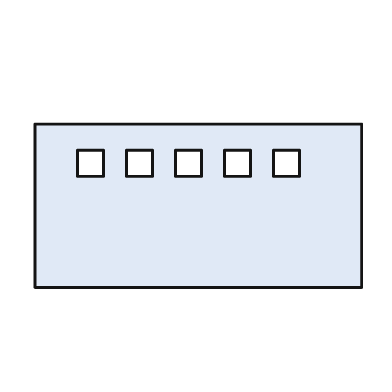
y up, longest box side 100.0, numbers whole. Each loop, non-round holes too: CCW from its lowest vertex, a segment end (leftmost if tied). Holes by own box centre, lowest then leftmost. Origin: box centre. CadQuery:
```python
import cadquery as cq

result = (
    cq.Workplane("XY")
    .moveTo(-50.0, -25.0)
    .lineTo(50.0, -25.0)
    .lineTo(50.0, 25.0)
    .lineTo(-50.0, 25.0)
    .close()
    .moveTo(-37.0, 9.0)
    .lineTo(-29.0, 9.0)
    .lineTo(-29.0, 17.0)
    .lineTo(-37.0, 17.0)
    .close()
    .moveTo(-22.0, 9.0)
    .lineTo(-14.0, 9.0)
    .lineTo(-14.0, 17.0)
    .lineTo(-22.0, 17.0)
    .close()
    .moveTo(-7.0, 9.0)
    .lineTo(1.0, 9.0)
    .lineTo(1.0, 17.0)
    .lineTo(-7.0, 17.0)
    .close()
    .moveTo(8.0, 9.0)
    .lineTo(16.0, 9.0)
    .lineTo(16.0, 17.0)
    .lineTo(8.0, 17.0)
    .close()
    .moveTo(23.0, 9.0)
    .lineTo(31.0, 9.0)
    .lineTo(31.0, 17.0)
    .lineTo(23.0, 17.0)
    .close()
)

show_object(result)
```